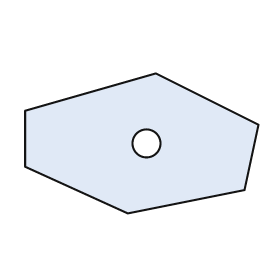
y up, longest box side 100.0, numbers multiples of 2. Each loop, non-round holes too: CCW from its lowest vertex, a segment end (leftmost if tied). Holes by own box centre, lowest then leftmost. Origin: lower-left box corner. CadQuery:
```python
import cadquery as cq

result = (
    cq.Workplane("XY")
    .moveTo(44.0, 0.0)
    .lineTo(94.0, 10.0)
    .lineTo(100.0, 38.0)
    .lineTo(56.0, 60.0)
    .lineTo(0.0, 44.0)
    .lineTo(0.0, 20.0)
    .close()
    .moveTo(52.0, 30.0)
    .circle(6.0)
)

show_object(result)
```